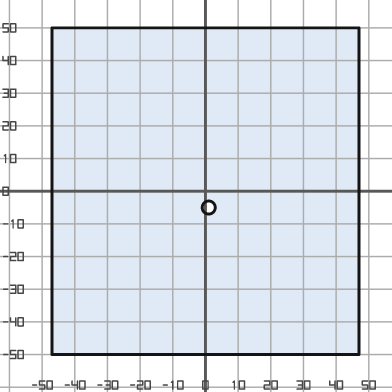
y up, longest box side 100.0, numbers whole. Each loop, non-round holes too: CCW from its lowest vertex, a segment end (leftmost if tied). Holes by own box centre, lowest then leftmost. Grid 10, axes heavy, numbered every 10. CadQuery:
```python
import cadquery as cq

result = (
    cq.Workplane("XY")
    .moveTo(-47.0, -50.0)
    .lineTo(47.0, -50.0)
    .lineTo(47.0, 50.0)
    .lineTo(-47.0, 50.0)
    .close()
    .moveTo(1.0, -5.0)
    .circle(2.0)
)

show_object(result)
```